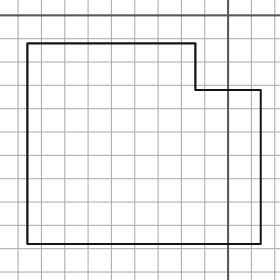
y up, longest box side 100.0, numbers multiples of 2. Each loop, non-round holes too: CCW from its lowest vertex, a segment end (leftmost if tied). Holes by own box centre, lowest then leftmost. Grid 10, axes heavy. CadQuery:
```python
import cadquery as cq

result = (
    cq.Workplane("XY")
    .moveTo(-86.0, -98.0)
    .lineTo(14.0, -98.0)
    .lineTo(14.0, -32.0)
    .lineTo(-14.0, -32.0)
    .lineTo(-14.0, -12.0)
    .lineTo(-86.0, -12.0)
    .close()
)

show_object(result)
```